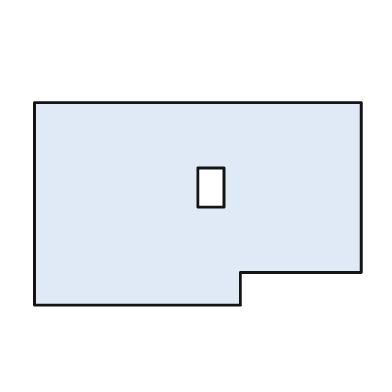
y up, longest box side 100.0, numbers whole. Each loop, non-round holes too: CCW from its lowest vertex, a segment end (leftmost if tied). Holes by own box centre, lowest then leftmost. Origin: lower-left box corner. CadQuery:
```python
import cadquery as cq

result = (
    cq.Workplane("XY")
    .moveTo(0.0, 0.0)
    .lineTo(63.0, 0.0)
    .lineTo(63.0, 10.0)
    .lineTo(100.0, 10.0)
    .lineTo(100.0, 62.0)
    .lineTo(0.0, 62.0)
    .close()
    .moveTo(50.0, 30.0)
    .lineTo(58.0, 30.0)
    .lineTo(58.0, 42.0)
    .lineTo(50.0, 42.0)
    .close()
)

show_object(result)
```